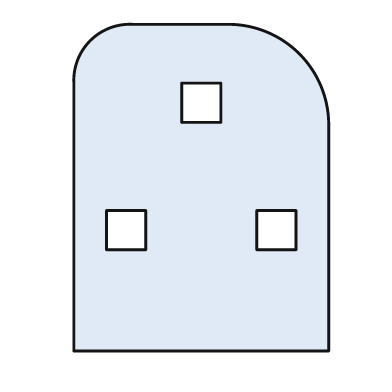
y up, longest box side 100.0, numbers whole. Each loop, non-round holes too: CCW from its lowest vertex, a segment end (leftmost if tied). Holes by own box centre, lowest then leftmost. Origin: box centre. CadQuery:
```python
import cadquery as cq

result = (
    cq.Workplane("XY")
    .moveTo(-39.0, -50.0)
    .lineTo(39.0, -50.0)
    .lineTo(39.0, 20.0)
    .threePointArc((30.0, 41.0), (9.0, 50.0))
    .lineTo(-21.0, 50.0)
    .threePointArc((-34.0, 45.0), (-39.0, 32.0))
    .close()
    .moveTo(-29.0, -19.0)
    .lineTo(-17.0, -19.0)
    .lineTo(-17.0, -7.0)
    .lineTo(-29.0, -7.0)
    .close()
    .moveTo(17.0, -19.0)
    .lineTo(29.0, -19.0)
    .lineTo(29.0, -7.0)
    .lineTo(17.0, -7.0)
    .close()
    .moveTo(-6.0, 20.0)
    .lineTo(6.0, 20.0)
    .lineTo(6.0, 32.0)
    .lineTo(-6.0, 32.0)
    .close()
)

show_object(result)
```